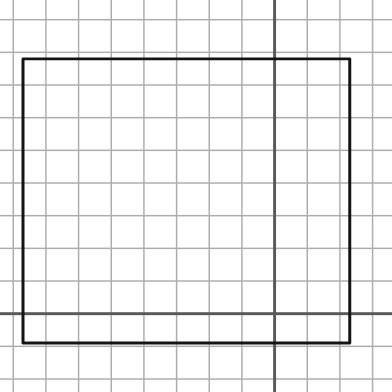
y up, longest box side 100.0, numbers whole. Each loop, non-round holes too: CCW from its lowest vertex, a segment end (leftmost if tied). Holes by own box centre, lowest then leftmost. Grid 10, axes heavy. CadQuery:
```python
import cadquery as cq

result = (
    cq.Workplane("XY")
    .moveTo(-77.0, -9.0)
    .lineTo(23.0, -9.0)
    .lineTo(23.0, 78.0)
    .lineTo(-77.0, 78.0)
    .close()
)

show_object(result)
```